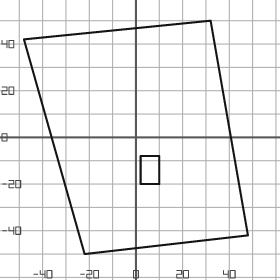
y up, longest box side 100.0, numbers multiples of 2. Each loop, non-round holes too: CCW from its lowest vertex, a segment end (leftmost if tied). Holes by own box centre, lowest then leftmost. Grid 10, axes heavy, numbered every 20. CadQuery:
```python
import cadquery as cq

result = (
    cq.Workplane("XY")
    .moveTo(-22.0, -50.0)
    .lineTo(48.0, -42.0)
    .lineTo(32.0, 50.0)
    .lineTo(-48.0, 42.0)
    .close()
    .moveTo(2.0, -20.0)
    .lineTo(10.0, -20.0)
    .lineTo(10.0, -8.0)
    .lineTo(2.0, -8.0)
    .close()
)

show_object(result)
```